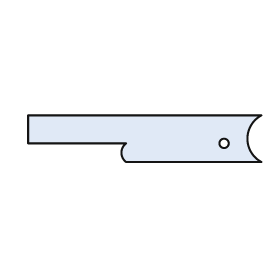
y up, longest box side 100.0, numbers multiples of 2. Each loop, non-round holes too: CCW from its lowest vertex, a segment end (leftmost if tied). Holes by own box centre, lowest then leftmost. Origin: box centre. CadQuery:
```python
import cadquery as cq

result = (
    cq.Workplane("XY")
    .moveTo(-8.0, -10.0)
    .lineTo(50.0, -10.0)
    .threePointArc((44.0, 0.0), (50.0, 10.0))
    .lineTo(-50.0, 10.0)
    .lineTo(-50.0, -2.0)
    .lineTo(-8.0, -2.0)
    .threePointArc((-10.0, -6.0), (-8.0, -10.0))
    .close()
    .moveTo(34.0, -2.0)
    .circle(2.0)
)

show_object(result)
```